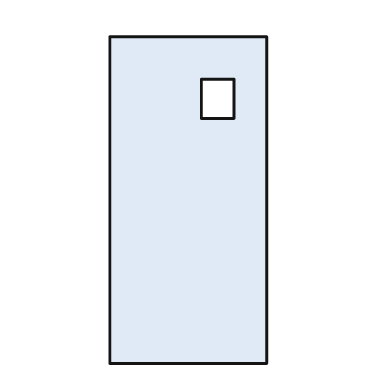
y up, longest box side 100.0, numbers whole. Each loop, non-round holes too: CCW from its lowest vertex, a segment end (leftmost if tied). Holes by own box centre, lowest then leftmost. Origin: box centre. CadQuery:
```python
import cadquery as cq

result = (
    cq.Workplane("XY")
    .moveTo(-24.0, -50.0)
    .lineTo(24.0, -50.0)
    .lineTo(24.0, 50.0)
    .lineTo(-24.0, 50.0)
    .close()
    .moveTo(4.0, 25.0)
    .lineTo(14.0, 25.0)
    .lineTo(14.0, 37.0)
    .lineTo(4.0, 37.0)
    .close()
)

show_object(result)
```